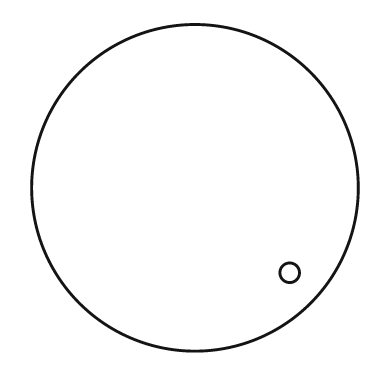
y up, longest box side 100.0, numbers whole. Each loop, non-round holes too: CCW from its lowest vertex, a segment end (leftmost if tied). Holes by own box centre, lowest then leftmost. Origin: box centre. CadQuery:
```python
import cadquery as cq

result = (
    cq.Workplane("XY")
    .moveTo(0.0, 0.0)
    .circle(50.0)
    .moveTo(29.0, -26.0)
    .circle(3.0)
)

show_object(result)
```